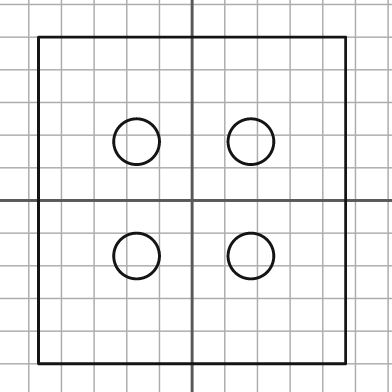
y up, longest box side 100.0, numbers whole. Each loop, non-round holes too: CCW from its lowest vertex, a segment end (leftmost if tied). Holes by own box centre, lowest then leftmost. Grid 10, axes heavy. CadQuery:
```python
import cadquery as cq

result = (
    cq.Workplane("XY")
    .moveTo(-47.0, -50.0)
    .lineTo(47.0, -50.0)
    .lineTo(47.0, 50.0)
    .lineTo(-47.0, 50.0)
    .close()
    .moveTo(-17.0, -17.0)
    .circle(7.0)
    .moveTo(18.0, -17.0)
    .circle(7.0)
    .moveTo(-17.0, 18.0)
    .circle(7.0)
    .moveTo(18.0, 18.0)
    .circle(7.0)
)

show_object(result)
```